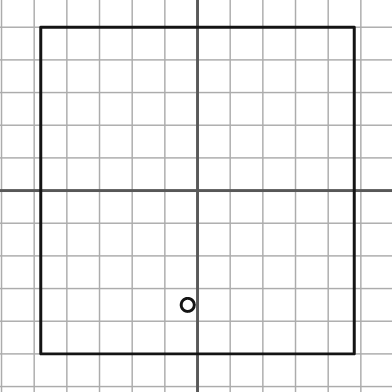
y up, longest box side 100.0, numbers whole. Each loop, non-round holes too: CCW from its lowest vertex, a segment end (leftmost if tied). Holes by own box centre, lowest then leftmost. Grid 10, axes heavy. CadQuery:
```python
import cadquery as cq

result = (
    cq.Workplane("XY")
    .moveTo(-48.0, -50.0)
    .lineTo(48.0, -50.0)
    .lineTo(48.0, 50.0)
    .lineTo(-48.0, 50.0)
    .close()
    .moveTo(-3.0, -35.0)
    .circle(2.0)
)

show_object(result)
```